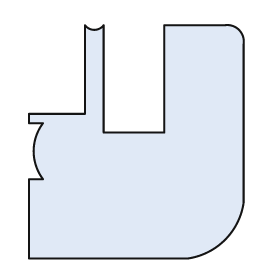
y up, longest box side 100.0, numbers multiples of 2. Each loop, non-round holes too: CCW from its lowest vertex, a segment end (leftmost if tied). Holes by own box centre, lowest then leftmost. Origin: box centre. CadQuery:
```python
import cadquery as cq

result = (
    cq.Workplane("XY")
    .moveTo(-46.0, -50.0)
    .lineTo(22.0, -50.0)
    .threePointArc((38.0, -42.0), (46.0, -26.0))
    .lineTo(46.0, 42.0)
    .threePointArc((44.0, 48.0), (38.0, 50.0))
    .lineTo(12.0, 50.0)
    .lineTo(12.0, 4.0)
    .lineTo(-14.0, 4.0)
    .lineTo(-14.0, 50.0)
    .threePointArc((-18.0, 48.0), (-22.0, 50.0))
    .lineTo(-22.0, 12.0)
    .lineTo(-46.0, 12.0)
    .lineTo(-46.0, 8.0)
    .lineTo(-40.0, 8.0)
    .threePointArc((-44.0, -4.0), (-40.0, -16.0))
    .lineTo(-46.0, -16.0)
    .close()
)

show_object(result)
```